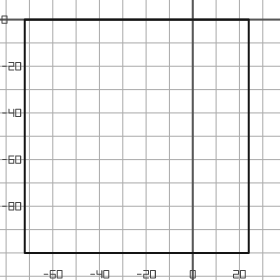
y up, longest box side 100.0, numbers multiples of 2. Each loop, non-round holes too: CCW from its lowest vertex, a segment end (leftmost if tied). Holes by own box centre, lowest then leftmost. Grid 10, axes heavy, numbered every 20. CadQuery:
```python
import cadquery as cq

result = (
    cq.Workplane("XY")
    .moveTo(-72.0, -100.0)
    .lineTo(24.0, -100.0)
    .lineTo(24.0, 0.0)
    .lineTo(-72.0, 0.0)
    .close()
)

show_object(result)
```